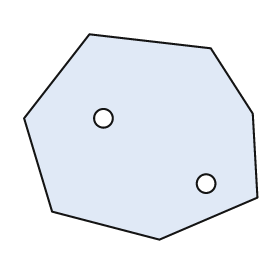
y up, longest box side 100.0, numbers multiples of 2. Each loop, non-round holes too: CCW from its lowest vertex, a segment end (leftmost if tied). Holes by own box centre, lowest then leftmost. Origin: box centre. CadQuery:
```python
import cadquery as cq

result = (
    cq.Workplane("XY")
    .moveTo(8.0, -44.0)
    .lineTo(50.0, -26.0)
    .lineTo(48.0, 10.0)
    .lineTo(30.0, 38.0)
    .lineTo(-22.0, 44.0)
    .lineTo(-50.0, 8.0)
    .lineTo(-38.0, -32.0)
    .close()
    .moveTo(28.0, -20.0)
    .circle(4.0)
    .moveTo(-16.0, 8.0)
    .circle(4.0)
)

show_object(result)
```